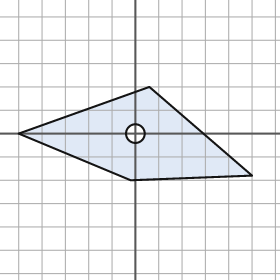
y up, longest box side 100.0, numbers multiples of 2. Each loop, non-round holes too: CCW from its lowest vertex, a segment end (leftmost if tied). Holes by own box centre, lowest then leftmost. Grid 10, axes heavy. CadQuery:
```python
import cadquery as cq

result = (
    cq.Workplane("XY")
    .moveTo(-2.0, -20.0)
    .lineTo(50.0, -18.0)
    .lineTo(6.0, 20.0)
    .lineTo(-50.0, 0.0)
    .close()
    .moveTo(0.0, 0.0)
    .circle(4.0)
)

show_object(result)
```